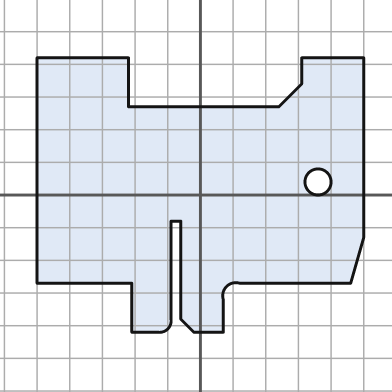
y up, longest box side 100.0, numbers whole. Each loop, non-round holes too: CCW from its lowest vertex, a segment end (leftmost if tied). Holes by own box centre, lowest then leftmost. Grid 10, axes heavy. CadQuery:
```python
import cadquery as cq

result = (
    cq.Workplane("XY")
    .moveTo(-21.0, -42.0)
    .lineTo(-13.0, -42.0)
    .threePointArc((-10.0, -41.0), (-9.0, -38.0))
    .lineTo(-9.0, -8.0)
    .lineTo(-6.0, -8.0)
    .lineTo(-6.0, -38.0)
    .lineTo(-2.0, -42.0)
    .lineTo(7.0, -42.0)
    .lineTo(7.0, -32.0)
    .threePointArc((8.0, -28.0), (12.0, -27.0))
    .lineTo(46.0, -27.0)
    .lineTo(50.0, -13.0)
    .lineTo(50.0, 42.0)
    .lineTo(31.0, 42.0)
    .lineTo(31.0, 34.0)
    .lineTo(24.0, 27.0)
    .lineTo(-22.0, 27.0)
    .lineTo(-22.0, 42.0)
    .lineTo(-50.0, 42.0)
    .lineTo(-50.0, -27.0)
    .lineTo(-21.0, -27.0)
    .close()
    .moveTo(36.0, 4.0)
    .circle(4.0)
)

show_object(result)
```